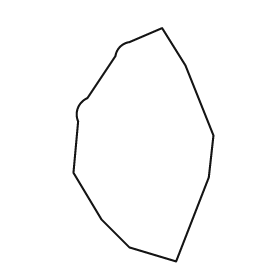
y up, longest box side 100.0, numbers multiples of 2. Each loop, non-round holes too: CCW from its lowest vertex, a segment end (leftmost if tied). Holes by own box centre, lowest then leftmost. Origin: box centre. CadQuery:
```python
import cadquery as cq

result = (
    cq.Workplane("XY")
    .moveTo(14.0, -50.0)
    .lineTo(28.0, -14.0)
    .lineTo(30.0, 4.0)
    .lineTo(18.0, 34.0)
    .lineTo(8.0, 50.0)
    .lineTo(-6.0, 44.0)
    .threePointArc((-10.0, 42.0), (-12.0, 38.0))
    .lineTo(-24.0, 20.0)
    .threePointArc((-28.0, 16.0), (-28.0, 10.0))
    .lineTo(-30.0, -12.0)
    .lineTo(-18.0, -32.0)
    .lineTo(-6.0, -44.0)
    .close()
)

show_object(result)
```